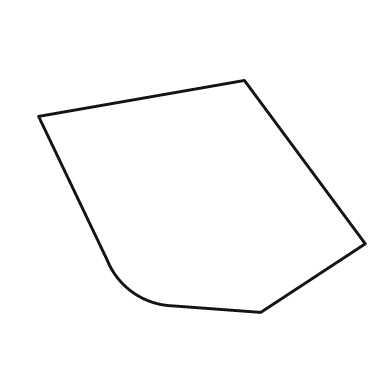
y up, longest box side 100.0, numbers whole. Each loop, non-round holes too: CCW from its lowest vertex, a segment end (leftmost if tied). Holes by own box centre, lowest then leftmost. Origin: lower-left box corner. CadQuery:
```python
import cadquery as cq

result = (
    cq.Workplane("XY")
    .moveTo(68.0, 0.0)
    .lineTo(100.0, 21.0)
    .lineTo(63.0, 71.0)
    .lineTo(0.0, 60.0)
    .lineTo(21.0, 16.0)
    .threePointArc((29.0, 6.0), (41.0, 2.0))
    .close()
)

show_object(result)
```